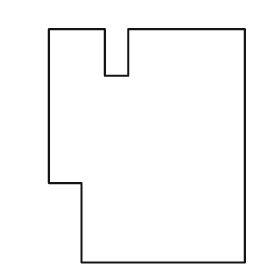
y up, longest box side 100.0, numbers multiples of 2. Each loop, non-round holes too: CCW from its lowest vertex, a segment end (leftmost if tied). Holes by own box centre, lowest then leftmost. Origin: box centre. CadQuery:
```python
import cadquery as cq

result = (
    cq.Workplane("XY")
    .moveTo(-28.0, -50.0)
    .lineTo(42.0, -50.0)
    .lineTo(42.0, 50.0)
    .lineTo(-8.0, 50.0)
    .lineTo(-8.0, 30.0)
    .lineTo(-18.0, 30.0)
    .lineTo(-18.0, 50.0)
    .lineTo(-42.0, 50.0)
    .lineTo(-42.0, -16.0)
    .lineTo(-28.0, -16.0)
    .close()
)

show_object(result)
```